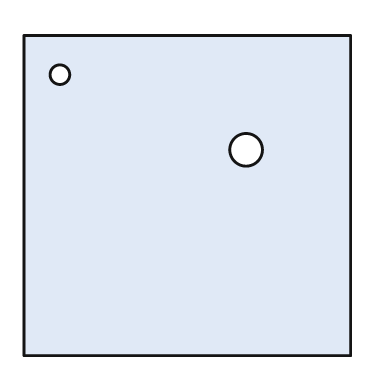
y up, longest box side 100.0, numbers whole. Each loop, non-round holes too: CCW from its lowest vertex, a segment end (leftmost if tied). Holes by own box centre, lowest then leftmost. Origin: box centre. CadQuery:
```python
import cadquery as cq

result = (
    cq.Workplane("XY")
    .moveTo(-50.0, -49.0)
    .lineTo(50.0, -49.0)
    .lineTo(50.0, 49.0)
    .lineTo(-50.0, 49.0)
    .close()
    .moveTo(18.0, 14.0)
    .circle(5.0)
    .moveTo(-39.0, 37.0)
    .circle(3.0)
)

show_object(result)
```